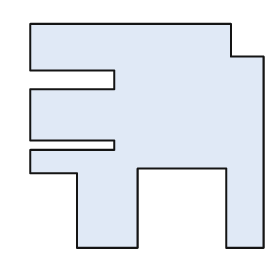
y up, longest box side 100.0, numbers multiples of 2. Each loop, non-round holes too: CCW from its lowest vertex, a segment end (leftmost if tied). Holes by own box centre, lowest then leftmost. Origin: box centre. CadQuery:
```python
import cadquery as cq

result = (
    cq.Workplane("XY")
    .moveTo(-30.0, -48.0)
    .lineTo(-4.0, -48.0)
    .lineTo(-4.0, -14.0)
    .lineTo(34.0, -14.0)
    .lineTo(34.0, -48.0)
    .lineTo(50.0, -48.0)
    .lineTo(50.0, 34.0)
    .lineTo(36.0, 34.0)
    .lineTo(36.0, 48.0)
    .lineTo(-50.0, 48.0)
    .lineTo(-50.0, 28.0)
    .lineTo(-14.0, 28.0)
    .lineTo(-14.0, 20.0)
    .lineTo(-50.0, 20.0)
    .lineTo(-50.0, -2.0)
    .lineTo(-14.0, -2.0)
    .lineTo(-14.0, -6.0)
    .lineTo(-50.0, -6.0)
    .lineTo(-50.0, -16.0)
    .lineTo(-30.0, -16.0)
    .close()
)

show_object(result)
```